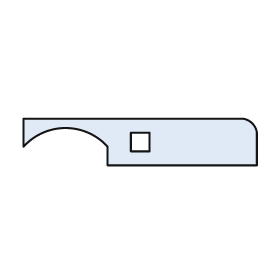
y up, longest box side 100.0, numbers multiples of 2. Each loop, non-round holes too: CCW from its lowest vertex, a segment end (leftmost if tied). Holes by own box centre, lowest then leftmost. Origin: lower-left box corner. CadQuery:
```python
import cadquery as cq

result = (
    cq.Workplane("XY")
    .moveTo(36.0, 0.0)
    .lineTo(100.0, 0.0)
    .lineTo(100.0, 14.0)
    .threePointArc((98.0, 18.0), (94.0, 20.0))
    .lineTo(0.0, 20.0)
    .lineTo(0.0, 8.0)
    .threePointArc((18.0, 16.0), (36.0, 8.0))
    .close()
    .moveTo(46.0, 6.0)
    .lineTo(54.0, 6.0)
    .lineTo(54.0, 14.0)
    .lineTo(46.0, 14.0)
    .close()
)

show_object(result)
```